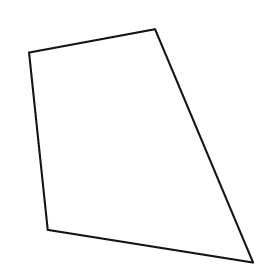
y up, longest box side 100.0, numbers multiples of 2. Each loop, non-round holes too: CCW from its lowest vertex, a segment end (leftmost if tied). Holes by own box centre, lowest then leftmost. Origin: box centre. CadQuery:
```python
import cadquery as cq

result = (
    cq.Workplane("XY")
    .moveTo(48.0, -50.0)
    .lineTo(6.0, 50.0)
    .lineTo(-48.0, 40.0)
    .lineTo(-40.0, -36.0)
    .close()
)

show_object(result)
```